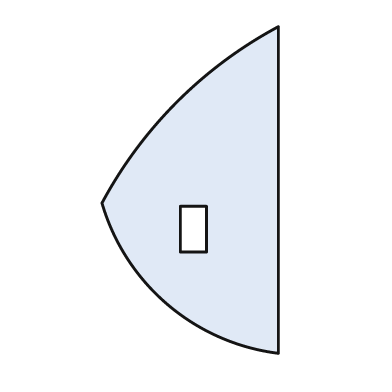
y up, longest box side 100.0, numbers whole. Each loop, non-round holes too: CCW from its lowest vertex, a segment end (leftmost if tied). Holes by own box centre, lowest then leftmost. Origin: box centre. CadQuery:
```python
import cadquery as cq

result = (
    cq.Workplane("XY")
    .moveTo(27.0, -50.0)
    .lineTo(27.0, 50.0)
    .threePointArc((-4.0, 27.0), (-27.0, -4.0))
    .threePointArc((-7.0, -35.0), (27.0, -50.0))
    .close()
    .moveTo(-3.0, -19.0)
    .lineTo(5.0, -19.0)
    .lineTo(5.0, -5.0)
    .lineTo(-3.0, -5.0)
    .close()
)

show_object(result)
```